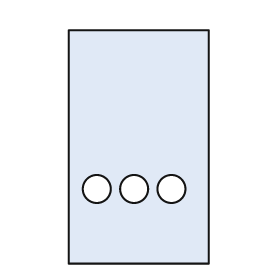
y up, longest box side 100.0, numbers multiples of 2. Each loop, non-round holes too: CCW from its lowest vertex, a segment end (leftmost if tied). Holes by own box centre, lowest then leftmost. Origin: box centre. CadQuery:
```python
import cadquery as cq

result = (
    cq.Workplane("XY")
    .moveTo(-30.0, -50.0)
    .lineTo(30.0, -50.0)
    .lineTo(30.0, 50.0)
    .lineTo(-30.0, 50.0)
    .close()
    .moveTo(-18.0, -18.0)
    .circle(6.0)
    .moveTo(-2.0, -18.0)
    .circle(6.0)
    .moveTo(14.0, -18.0)
    .circle(6.0)
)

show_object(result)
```